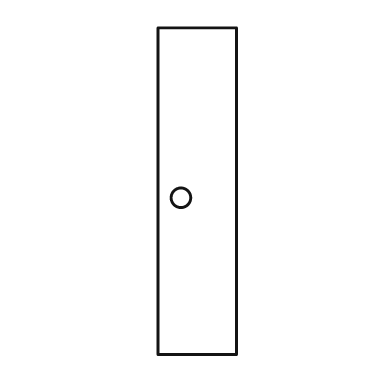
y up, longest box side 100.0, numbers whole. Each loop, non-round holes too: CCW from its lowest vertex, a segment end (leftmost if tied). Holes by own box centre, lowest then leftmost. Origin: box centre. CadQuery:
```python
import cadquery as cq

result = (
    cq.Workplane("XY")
    .moveTo(-12.0, -50.0)
    .lineTo(12.0, -50.0)
    .lineTo(12.0, 50.0)
    .lineTo(-12.0, 50.0)
    .close()
    .moveTo(-5.0, -2.0)
    .circle(3.0)
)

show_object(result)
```